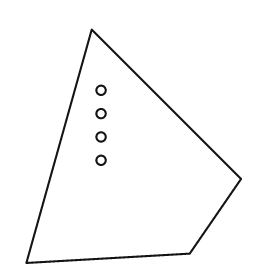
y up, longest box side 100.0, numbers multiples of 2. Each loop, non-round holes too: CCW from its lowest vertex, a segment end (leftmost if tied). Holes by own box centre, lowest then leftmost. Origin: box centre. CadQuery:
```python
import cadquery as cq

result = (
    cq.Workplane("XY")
    .moveTo(-46.0, -50.0)
    .lineTo(24.0, -46.0)
    .lineTo(46.0, -14.0)
    .lineTo(-18.0, 50.0)
    .close()
    .moveTo(-14.0, -6.0)
    .circle(2.0)
    .moveTo(-14.0, 4.0)
    .circle(2.0)
    .moveTo(-14.0, 14.0)
    .circle(2.0)
    .moveTo(-14.0, 24.0)
    .circle(2.0)
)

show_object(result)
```